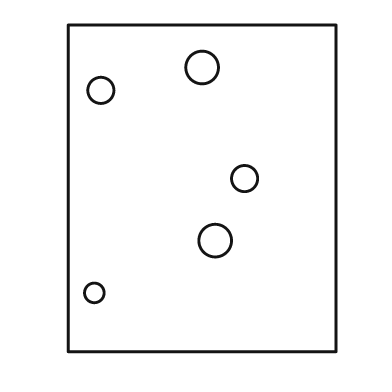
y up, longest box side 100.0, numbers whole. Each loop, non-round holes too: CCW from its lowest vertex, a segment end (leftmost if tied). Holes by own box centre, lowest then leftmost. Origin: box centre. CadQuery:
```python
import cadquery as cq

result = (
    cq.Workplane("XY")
    .moveTo(-41.0, -50.0)
    .lineTo(41.0, -50.0)
    .lineTo(41.0, 50.0)
    .lineTo(-41.0, 50.0)
    .close()
    .moveTo(-33.0, -32.0)
    .circle(3.0)
    .moveTo(4.0, -16.0)
    .circle(5.0)
    .moveTo(13.0, 3.0)
    .circle(4.0)
    .moveTo(-31.0, 30.0)
    .circle(4.0)
    .moveTo(0.0, 37.0)
    .circle(5.0)
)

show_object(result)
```